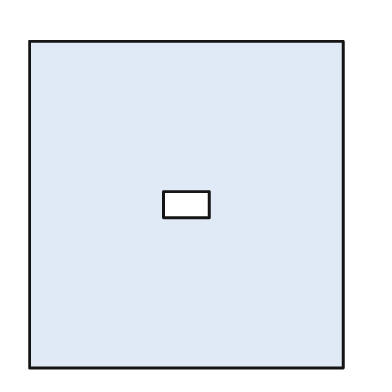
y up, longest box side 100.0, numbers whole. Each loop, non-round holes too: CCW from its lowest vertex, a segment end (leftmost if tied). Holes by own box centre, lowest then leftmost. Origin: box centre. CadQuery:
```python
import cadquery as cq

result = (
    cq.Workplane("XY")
    .moveTo(-48.0, -50.0)
    .lineTo(48.0, -50.0)
    .lineTo(48.0, 50.0)
    .lineTo(-48.0, 50.0)
    .close()
    .moveTo(-7.0, -4.0)
    .lineTo(7.0, -4.0)
    .lineTo(7.0, 4.0)
    .lineTo(-7.0, 4.0)
    .close()
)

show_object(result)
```